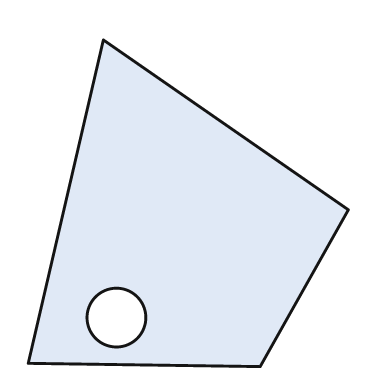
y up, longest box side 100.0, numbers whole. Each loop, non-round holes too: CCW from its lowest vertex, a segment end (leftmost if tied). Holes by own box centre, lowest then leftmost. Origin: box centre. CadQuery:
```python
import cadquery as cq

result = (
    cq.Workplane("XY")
    .moveTo(22.0, -50.0)
    .lineTo(49.0, -2.0)
    .lineTo(-26.0, 50.0)
    .lineTo(-49.0, -49.0)
    .close()
    .moveTo(-22.0, -35.0)
    .circle(9.0)
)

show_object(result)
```